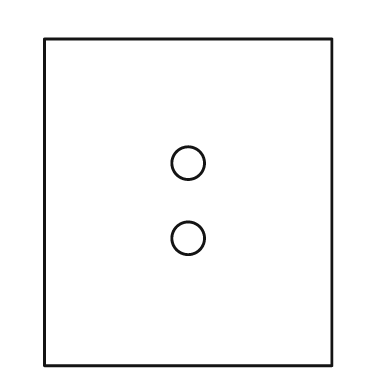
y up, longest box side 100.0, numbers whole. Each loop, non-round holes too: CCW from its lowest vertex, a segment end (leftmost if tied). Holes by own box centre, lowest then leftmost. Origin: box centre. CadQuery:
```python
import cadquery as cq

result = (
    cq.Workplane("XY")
    .moveTo(-44.0, -50.0)
    .lineTo(44.0, -50.0)
    .lineTo(44.0, 50.0)
    .lineTo(-44.0, 50.0)
    .close()
    .moveTo(0.0, -11.0)
    .circle(5.0)
    .moveTo(0.0, 12.0)
    .circle(5.0)
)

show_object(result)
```